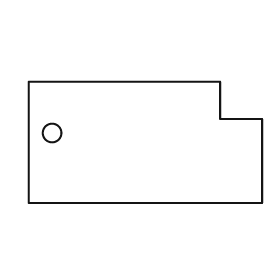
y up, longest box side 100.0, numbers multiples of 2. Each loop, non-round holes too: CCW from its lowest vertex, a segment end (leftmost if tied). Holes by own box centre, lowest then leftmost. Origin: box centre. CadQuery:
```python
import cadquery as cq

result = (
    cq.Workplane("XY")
    .moveTo(-50.0, -26.0)
    .lineTo(50.0, -26.0)
    .lineTo(50.0, 10.0)
    .lineTo(32.0, 10.0)
    .lineTo(32.0, 26.0)
    .lineTo(-50.0, 26.0)
    .close()
    .moveTo(-40.0, 4.0)
    .circle(4.0)
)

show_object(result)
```